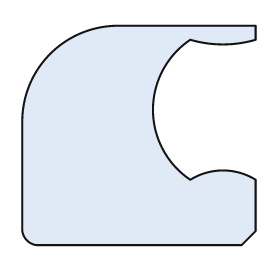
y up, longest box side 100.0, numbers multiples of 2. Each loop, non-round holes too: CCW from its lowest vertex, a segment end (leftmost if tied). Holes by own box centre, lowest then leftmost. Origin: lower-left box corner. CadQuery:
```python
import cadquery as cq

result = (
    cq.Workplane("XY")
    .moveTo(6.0, 0.0)
    .lineTo(94.0, 0.0)
    .lineTo(100.0, 6.0)
    .lineTo(100.0, 28.0)
    .threePointArc((86.0, 32.0), (72.0, 28.0))
    .threePointArc((56.0, 58.0), (72.0, 88.0))
    .threePointArc((86.0, 86.0), (100.0, 88.0))
    .lineTo(100.0, 94.0)
    .lineTo(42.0, 94.0)
    .threePointArc((12.0, 82.0), (0.0, 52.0))
    .lineTo(0.0, 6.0)
    .threePointArc((2.0, 2.0), (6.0, 0.0))
    .close()
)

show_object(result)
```